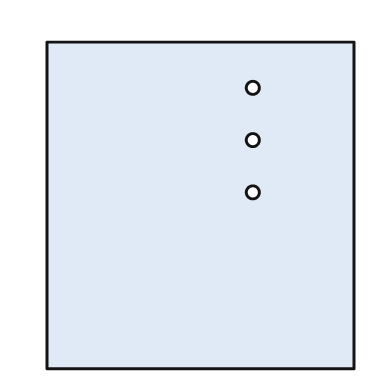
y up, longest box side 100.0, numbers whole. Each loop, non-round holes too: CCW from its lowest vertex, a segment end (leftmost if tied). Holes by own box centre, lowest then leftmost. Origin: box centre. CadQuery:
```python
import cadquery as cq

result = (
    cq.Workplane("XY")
    .moveTo(-47.0, -50.0)
    .lineTo(47.0, -50.0)
    .lineTo(47.0, 50.0)
    .lineTo(-47.0, 50.0)
    .close()
    .moveTo(16.0, 4.0)
    .circle(2.0)
    .moveTo(16.0, 20.0)
    .circle(2.0)
    .moveTo(16.0, 36.0)
    .circle(2.0)
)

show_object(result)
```